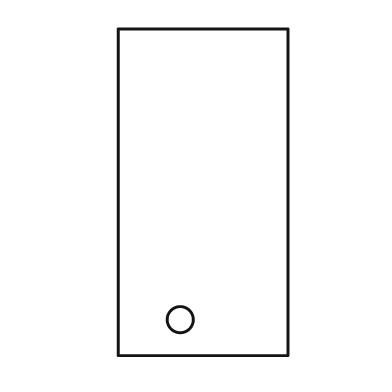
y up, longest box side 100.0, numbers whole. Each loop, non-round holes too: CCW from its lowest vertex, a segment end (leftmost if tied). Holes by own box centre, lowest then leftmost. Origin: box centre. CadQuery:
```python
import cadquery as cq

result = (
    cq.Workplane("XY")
    .moveTo(-26.0, -50.0)
    .lineTo(26.0, -50.0)
    .lineTo(26.0, 50.0)
    .lineTo(-26.0, 50.0)
    .close()
    .moveTo(-7.0, -39.0)
    .circle(4.0)
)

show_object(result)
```